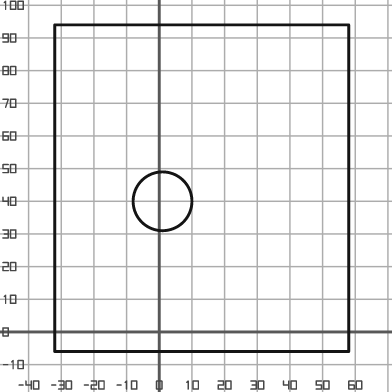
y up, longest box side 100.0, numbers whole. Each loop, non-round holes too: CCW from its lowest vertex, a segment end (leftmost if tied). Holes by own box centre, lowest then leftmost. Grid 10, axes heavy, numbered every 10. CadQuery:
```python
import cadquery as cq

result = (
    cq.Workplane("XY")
    .moveTo(-32.0, -6.0)
    .lineTo(58.0, -6.0)
    .lineTo(58.0, 94.0)
    .lineTo(-32.0, 94.0)
    .close()
    .moveTo(1.0, 40.0)
    .circle(9.0)
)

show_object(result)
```